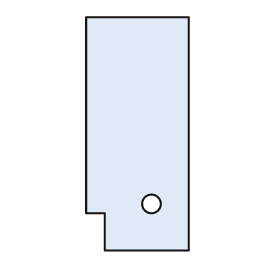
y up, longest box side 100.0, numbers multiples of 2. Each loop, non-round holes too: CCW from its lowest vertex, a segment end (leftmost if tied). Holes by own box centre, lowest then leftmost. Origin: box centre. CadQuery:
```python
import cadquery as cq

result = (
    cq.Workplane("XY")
    .moveTo(-14.0, -50.0)
    .lineTo(22.0, -50.0)
    .lineTo(22.0, 50.0)
    .lineTo(-22.0, 50.0)
    .lineTo(-22.0, -34.0)
    .lineTo(-14.0, -34.0)
    .close()
    .moveTo(6.0, -30.0)
    .circle(4.0)
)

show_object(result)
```